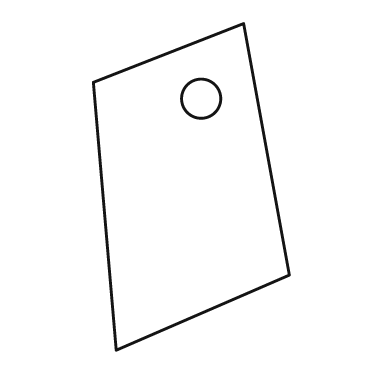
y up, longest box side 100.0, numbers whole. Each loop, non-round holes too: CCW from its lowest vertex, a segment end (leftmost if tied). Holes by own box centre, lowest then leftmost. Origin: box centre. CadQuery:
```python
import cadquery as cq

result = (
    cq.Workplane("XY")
    .moveTo(-23.0, -50.0)
    .lineTo(30.0, -27.0)
    .lineTo(16.0, 50.0)
    .lineTo(-30.0, 32.0)
    .close()
    .moveTo(3.0, 27.0)
    .circle(6.0)
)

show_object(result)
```